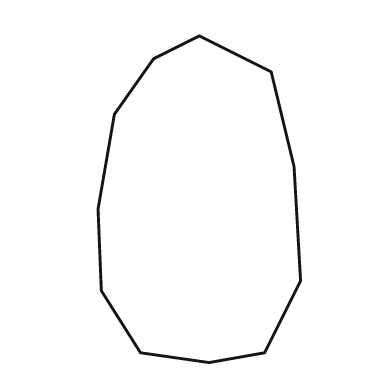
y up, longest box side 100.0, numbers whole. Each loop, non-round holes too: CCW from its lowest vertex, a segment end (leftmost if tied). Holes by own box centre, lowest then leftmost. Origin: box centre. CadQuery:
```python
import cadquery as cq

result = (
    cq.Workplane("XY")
    .moveTo(3.0, -50.0)
    .lineTo(20.0, -47.0)
    .lineTo(31.0, -25.0)
    .lineTo(29.0, 10.0)
    .lineTo(22.0, 39.0)
    .lineTo(0.0, 50.0)
    .lineTo(-14.0, 43.0)
    .lineTo(-26.0, 26.0)
    .lineTo(-31.0, -3.0)
    .lineTo(-30.0, -28.0)
    .lineTo(-18.0, -47.0)
    .close()
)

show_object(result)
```